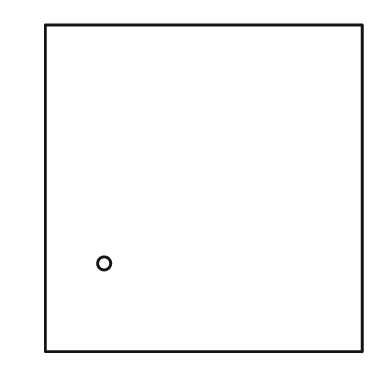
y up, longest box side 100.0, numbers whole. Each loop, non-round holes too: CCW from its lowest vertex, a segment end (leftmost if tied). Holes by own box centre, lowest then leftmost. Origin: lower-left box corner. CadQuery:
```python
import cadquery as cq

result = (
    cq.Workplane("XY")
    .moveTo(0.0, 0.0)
    .lineTo(97.0, 0.0)
    .lineTo(97.0, 100.0)
    .lineTo(0.0, 100.0)
    .close()
    .moveTo(18.0, 27.0)
    .circle(2.0)
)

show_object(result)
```